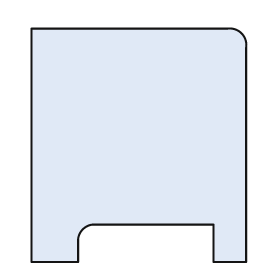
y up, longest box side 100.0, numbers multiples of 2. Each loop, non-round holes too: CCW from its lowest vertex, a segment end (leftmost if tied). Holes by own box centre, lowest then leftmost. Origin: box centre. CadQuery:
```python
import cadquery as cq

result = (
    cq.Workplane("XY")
    .moveTo(-46.0, -50.0)
    .lineTo(-26.0, -50.0)
    .lineTo(-26.0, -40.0)
    .threePointArc((-24.0, -36.0), (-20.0, -34.0))
    .lineTo(32.0, -34.0)
    .lineTo(32.0, -50.0)
    .lineTo(46.0, -50.0)
    .lineTo(46.0, 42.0)
    .threePointArc((44.0, 48.0), (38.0, 50.0))
    .lineTo(-46.0, 50.0)
    .close()
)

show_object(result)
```